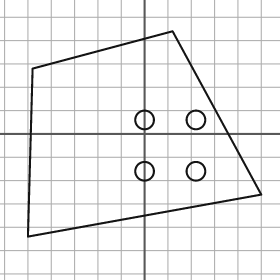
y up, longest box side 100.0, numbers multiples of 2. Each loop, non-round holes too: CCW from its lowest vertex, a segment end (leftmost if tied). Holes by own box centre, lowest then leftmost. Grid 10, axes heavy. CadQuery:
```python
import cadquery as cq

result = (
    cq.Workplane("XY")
    .moveTo(-50.0, -44.0)
    .lineTo(50.0, -26.0)
    .lineTo(12.0, 44.0)
    .lineTo(-48.0, 28.0)
    .close()
    .moveTo(0.0, -16.0)
    .circle(4.0)
    .moveTo(22.0, -16.0)
    .circle(4.0)
    .moveTo(0.0, 6.0)
    .circle(4.0)
    .moveTo(22.0, 6.0)
    .circle(4.0)
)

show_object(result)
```